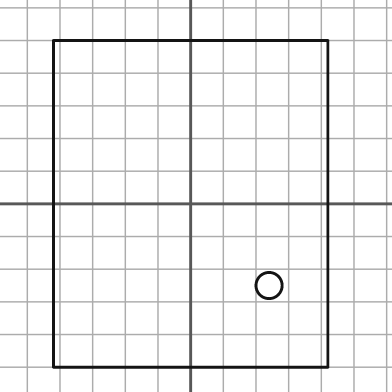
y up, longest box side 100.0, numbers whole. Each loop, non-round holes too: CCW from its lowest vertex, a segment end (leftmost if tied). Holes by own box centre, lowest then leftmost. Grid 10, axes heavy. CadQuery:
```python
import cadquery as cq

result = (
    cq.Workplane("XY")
    .moveTo(-42.0, -50.0)
    .lineTo(42.0, -50.0)
    .lineTo(42.0, 50.0)
    .lineTo(-42.0, 50.0)
    .close()
    .moveTo(24.0, -25.0)
    .circle(4.0)
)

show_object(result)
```